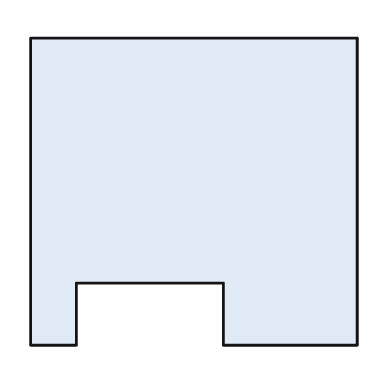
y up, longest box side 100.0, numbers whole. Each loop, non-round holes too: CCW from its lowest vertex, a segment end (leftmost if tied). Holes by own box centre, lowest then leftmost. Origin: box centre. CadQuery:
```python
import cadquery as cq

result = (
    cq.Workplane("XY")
    .moveTo(-50.0, -47.0)
    .lineTo(-36.0, -47.0)
    .lineTo(-36.0, -28.0)
    .lineTo(9.0, -28.0)
    .lineTo(9.0, -47.0)
    .lineTo(50.0, -47.0)
    .lineTo(50.0, 47.0)
    .lineTo(-50.0, 47.0)
    .close()
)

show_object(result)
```